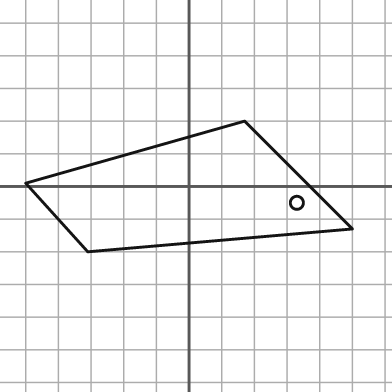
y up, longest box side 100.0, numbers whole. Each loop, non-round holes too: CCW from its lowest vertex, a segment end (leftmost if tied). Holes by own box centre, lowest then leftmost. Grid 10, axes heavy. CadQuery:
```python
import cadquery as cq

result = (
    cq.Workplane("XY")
    .moveTo(-31.0, -20.0)
    .lineTo(50.0, -13.0)
    .lineTo(17.0, 20.0)
    .lineTo(-50.0, 1.0)
    .close()
    .moveTo(33.0, -5.0)
    .circle(2.0)
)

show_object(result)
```